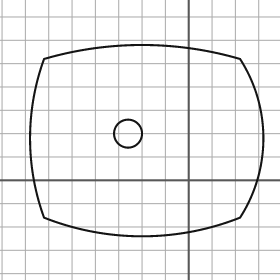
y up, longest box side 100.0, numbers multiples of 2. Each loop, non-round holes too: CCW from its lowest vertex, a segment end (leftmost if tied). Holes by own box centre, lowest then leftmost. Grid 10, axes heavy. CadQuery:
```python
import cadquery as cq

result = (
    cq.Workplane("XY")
    .moveTo(-62.0, -16.0)
    .threePointArc((-20.0, -24.0), (22.0, -16.0))
    .threePointArc((32.0, 18.0), (22.0, 52.0))
    .threePointArc((-20.0, 58.0), (-62.0, 52.0))
    .threePointArc((-68.0, 18.0), (-62.0, -16.0))
    .close()
    .moveTo(-26.0, 20.0)
    .circle(6.0)
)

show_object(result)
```